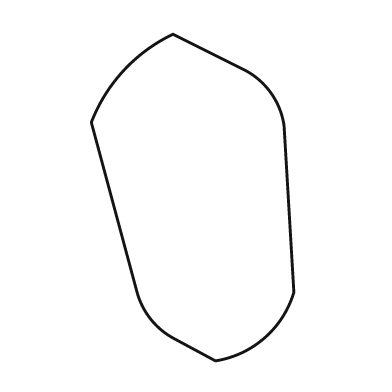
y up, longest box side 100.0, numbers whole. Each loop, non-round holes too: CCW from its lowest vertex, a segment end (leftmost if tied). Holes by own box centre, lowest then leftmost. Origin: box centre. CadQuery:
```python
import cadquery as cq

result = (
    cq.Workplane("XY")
    .moveTo(7.0, -50.0)
    .threePointArc((22.0, -43.0), (31.0, -29.0))
    .lineTo(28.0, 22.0)
    .threePointArc((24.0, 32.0), (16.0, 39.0))
    .lineTo(-6.0, 50.0)
    .threePointArc((-21.0, 39.0), (-31.0, 23.0))
    .lineTo(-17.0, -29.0)
    .threePointArc((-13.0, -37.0), (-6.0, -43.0))
    .close()
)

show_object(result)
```